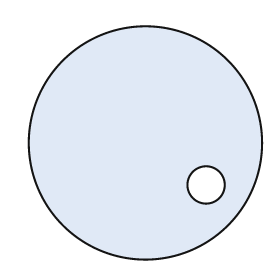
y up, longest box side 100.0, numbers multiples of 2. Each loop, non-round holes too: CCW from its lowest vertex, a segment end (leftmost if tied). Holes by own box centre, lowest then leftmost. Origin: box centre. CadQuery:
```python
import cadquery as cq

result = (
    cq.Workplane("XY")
    .moveTo(0.0, 0.0)
    .circle(50.0)
    .moveTo(26.0, -18.0)
    .circle(8.0)
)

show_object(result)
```